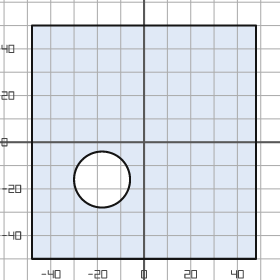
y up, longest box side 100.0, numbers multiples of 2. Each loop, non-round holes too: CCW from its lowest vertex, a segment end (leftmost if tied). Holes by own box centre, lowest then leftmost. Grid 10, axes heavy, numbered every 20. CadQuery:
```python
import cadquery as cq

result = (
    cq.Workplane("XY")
    .moveTo(-48.0, -50.0)
    .lineTo(48.0, -50.0)
    .lineTo(48.0, 50.0)
    .lineTo(-48.0, 50.0)
    .close()
    .moveTo(-18.0, -16.0)
    .circle(12.0)
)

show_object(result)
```